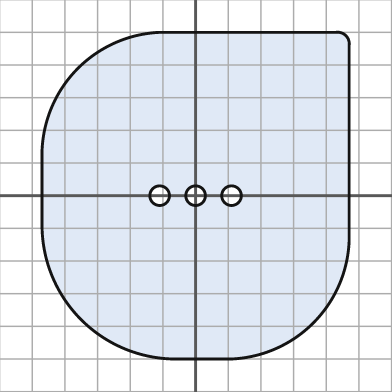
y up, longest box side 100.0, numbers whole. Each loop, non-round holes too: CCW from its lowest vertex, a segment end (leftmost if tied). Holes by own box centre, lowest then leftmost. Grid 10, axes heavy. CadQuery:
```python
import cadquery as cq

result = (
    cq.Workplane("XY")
    .moveTo(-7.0, -50.0)
    .lineTo(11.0, -50.0)
    .threePointArc((36.0, -39.0), (47.0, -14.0))
    .lineTo(47.0, 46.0)
    .threePointArc((46.0, 49.0), (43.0, 50.0))
    .lineTo(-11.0, 50.0)
    .threePointArc((-36.0, 39.0), (-47.0, 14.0))
    .lineTo(-47.0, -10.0)
    .threePointArc((-35.0, -38.0), (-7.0, -50.0))
    .close()
    .moveTo(-11.0, 0.0)
    .circle(3.0)
    .moveTo(0.0, 0.0)
    .circle(3.0)
    .moveTo(11.0, 0.0)
    .circle(3.0)
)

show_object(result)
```